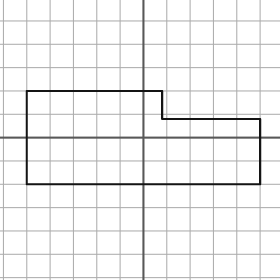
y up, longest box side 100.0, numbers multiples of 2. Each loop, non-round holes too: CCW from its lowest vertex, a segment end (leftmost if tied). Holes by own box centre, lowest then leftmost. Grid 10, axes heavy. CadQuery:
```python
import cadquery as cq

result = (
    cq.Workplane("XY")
    .moveTo(-50.0, -20.0)
    .lineTo(50.0, -20.0)
    .lineTo(50.0, 8.0)
    .lineTo(8.0, 8.0)
    .lineTo(8.0, 20.0)
    .lineTo(-50.0, 20.0)
    .close()
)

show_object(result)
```